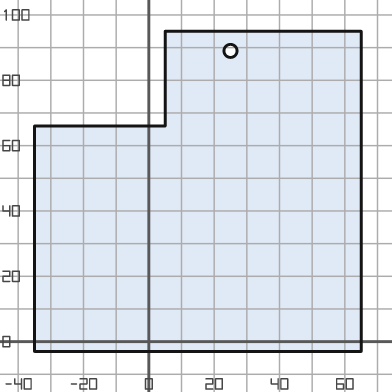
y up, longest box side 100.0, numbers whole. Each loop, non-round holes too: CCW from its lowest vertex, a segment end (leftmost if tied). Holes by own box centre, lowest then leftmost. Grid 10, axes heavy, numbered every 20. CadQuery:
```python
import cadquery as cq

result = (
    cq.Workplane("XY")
    .moveTo(-35.0, -3.0)
    .lineTo(65.0, -3.0)
    .lineTo(65.0, 95.0)
    .lineTo(5.0, 95.0)
    .lineTo(5.0, 66.0)
    .lineTo(-35.0, 66.0)
    .close()
    .moveTo(25.0, 89.0)
    .circle(2.0)
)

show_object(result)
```